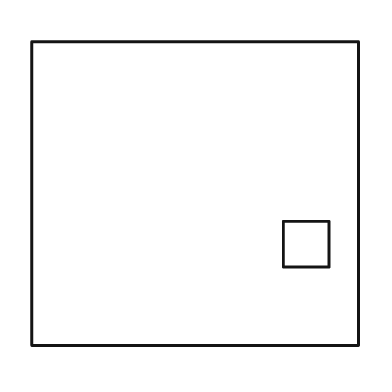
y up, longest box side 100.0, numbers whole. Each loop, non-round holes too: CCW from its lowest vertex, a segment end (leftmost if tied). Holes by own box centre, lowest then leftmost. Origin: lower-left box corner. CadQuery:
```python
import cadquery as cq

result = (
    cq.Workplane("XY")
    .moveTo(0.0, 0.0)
    .lineTo(100.0, 0.0)
    .lineTo(100.0, 93.0)
    .lineTo(0.0, 93.0)
    .close()
    .moveTo(77.0, 24.0)
    .lineTo(91.0, 24.0)
    .lineTo(91.0, 38.0)
    .lineTo(77.0, 38.0)
    .close()
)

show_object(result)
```